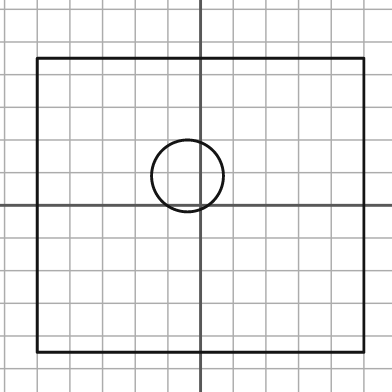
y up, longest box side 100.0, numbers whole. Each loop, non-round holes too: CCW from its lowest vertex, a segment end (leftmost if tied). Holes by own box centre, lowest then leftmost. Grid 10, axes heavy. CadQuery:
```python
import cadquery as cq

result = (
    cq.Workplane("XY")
    .moveTo(-50.0, -45.0)
    .lineTo(50.0, -45.0)
    .lineTo(50.0, 45.0)
    .lineTo(-50.0, 45.0)
    .close()
    .moveTo(-4.0, 9.0)
    .circle(11.0)
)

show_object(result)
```